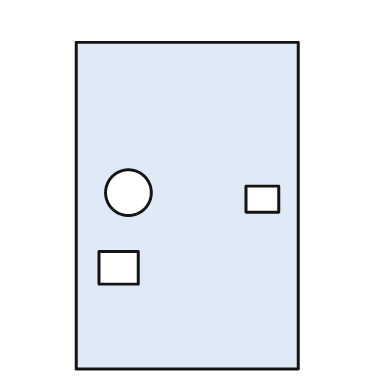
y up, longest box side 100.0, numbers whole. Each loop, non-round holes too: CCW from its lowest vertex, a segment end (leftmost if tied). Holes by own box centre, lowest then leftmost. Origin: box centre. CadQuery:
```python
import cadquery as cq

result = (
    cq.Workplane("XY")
    .moveTo(-34.0, -50.0)
    .lineTo(34.0, -50.0)
    .lineTo(34.0, 50.0)
    .lineTo(-34.0, 50.0)
    .close()
    .moveTo(-27.0, -24.0)
    .lineTo(-15.0, -24.0)
    .lineTo(-15.0, -14.0)
    .lineTo(-27.0, -14.0)
    .close()
    .moveTo(18.0, -2.0)
    .lineTo(28.0, -2.0)
    .lineTo(28.0, 6.0)
    .lineTo(18.0, 6.0)
    .close()
    .moveTo(-18.0, 4.0)
    .circle(7.0)
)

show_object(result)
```